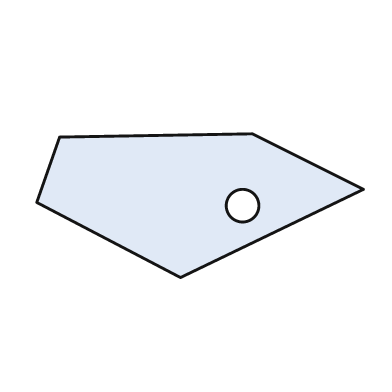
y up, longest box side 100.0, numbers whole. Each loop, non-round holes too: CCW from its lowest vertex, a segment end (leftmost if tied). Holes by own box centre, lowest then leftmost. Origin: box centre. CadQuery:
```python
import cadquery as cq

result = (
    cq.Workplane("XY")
    .moveTo(-6.0, -22.0)
    .lineTo(50.0, 5.0)
    .lineTo(16.0, 22.0)
    .lineTo(-43.0, 21.0)
    .lineTo(-50.0, 1.0)
    .close()
    .moveTo(13.0, 0.0)
    .circle(5.0)
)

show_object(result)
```